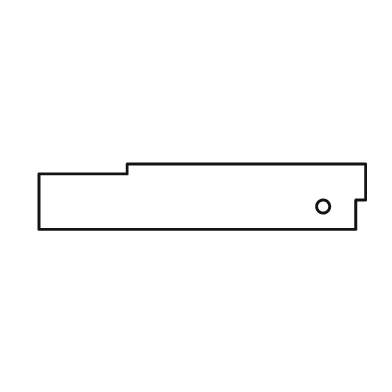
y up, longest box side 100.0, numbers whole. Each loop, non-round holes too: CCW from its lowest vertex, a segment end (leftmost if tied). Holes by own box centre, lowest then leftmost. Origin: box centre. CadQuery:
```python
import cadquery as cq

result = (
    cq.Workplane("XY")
    .moveTo(-50.0, -10.0)
    .lineTo(47.0, -10.0)
    .lineTo(47.0, -1.0)
    .lineTo(50.0, -1.0)
    .lineTo(50.0, 10.0)
    .lineTo(-23.0, 10.0)
    .lineTo(-23.0, 7.0)
    .lineTo(-50.0, 7.0)
    .close()
    .moveTo(37.0, -3.0)
    .circle(2.0)
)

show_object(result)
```